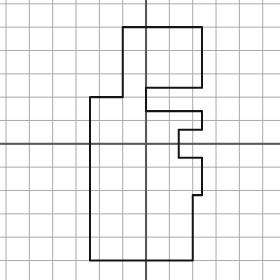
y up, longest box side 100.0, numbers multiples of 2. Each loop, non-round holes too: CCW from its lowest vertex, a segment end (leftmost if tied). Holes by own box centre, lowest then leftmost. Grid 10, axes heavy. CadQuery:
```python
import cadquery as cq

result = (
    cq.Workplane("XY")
    .moveTo(-24.0, -50.0)
    .lineTo(20.0, -50.0)
    .lineTo(20.0, -22.0)
    .lineTo(24.0, -22.0)
    .lineTo(24.0, -6.0)
    .lineTo(14.0, -6.0)
    .lineTo(14.0, 6.0)
    .lineTo(24.0, 6.0)
    .lineTo(24.0, 14.0)
    .lineTo(0.0, 14.0)
    .lineTo(0.0, 24.0)
    .lineTo(24.0, 24.0)
    .lineTo(24.0, 50.0)
    .lineTo(-10.0, 50.0)
    .lineTo(-10.0, 20.0)
    .lineTo(-24.0, 20.0)
    .close()
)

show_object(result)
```